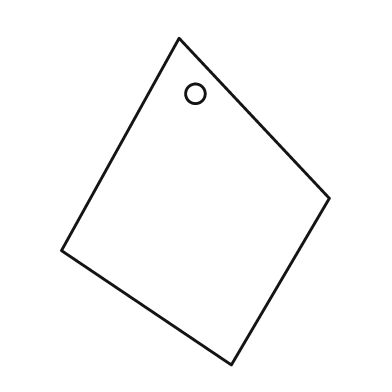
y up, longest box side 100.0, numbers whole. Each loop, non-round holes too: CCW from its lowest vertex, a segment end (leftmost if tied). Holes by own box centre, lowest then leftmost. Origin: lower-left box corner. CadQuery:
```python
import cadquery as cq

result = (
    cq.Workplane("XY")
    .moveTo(52.0, 0.0)
    .lineTo(82.0, 51.0)
    .lineTo(36.0, 100.0)
    .lineTo(0.0, 35.0)
    .close()
    .moveTo(41.0, 83.0)
    .circle(3.0)
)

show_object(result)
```